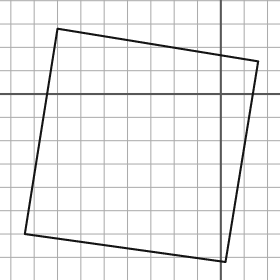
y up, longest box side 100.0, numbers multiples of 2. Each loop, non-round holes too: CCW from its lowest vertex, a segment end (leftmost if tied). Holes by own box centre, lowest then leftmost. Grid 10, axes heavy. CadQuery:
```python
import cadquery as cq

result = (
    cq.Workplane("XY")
    .moveTo(2.0, -72.0)
    .lineTo(16.0, 14.0)
    .lineTo(-70.0, 28.0)
    .lineTo(-84.0, -60.0)
    .close()
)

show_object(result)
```